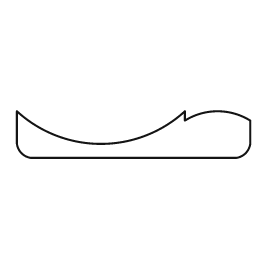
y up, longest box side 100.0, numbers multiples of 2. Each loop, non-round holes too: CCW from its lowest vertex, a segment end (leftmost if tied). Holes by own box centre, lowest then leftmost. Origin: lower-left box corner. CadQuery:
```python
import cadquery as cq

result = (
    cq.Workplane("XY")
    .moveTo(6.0, 0.0)
    .lineTo(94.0, 0.0)
    .threePointArc((98.0, 2.0), (100.0, 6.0))
    .lineTo(100.0, 16.0)
    .threePointArc((86.0, 20.0), (72.0, 16.0))
    .lineTo(72.0, 20.0)
    .threePointArc((36.0, 6.0), (0.0, 20.0))
    .lineTo(0.0, 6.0)
    .threePointArc((2.0, 2.0), (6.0, 0.0))
    .close()
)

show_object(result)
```